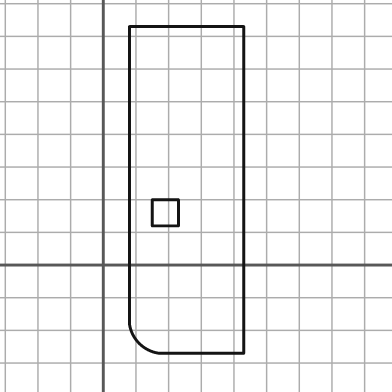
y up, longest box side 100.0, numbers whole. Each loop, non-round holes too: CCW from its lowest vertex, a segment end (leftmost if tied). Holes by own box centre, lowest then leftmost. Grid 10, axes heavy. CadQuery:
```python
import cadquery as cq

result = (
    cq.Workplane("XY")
    .moveTo(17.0, -27.0)
    .lineTo(43.0, -27.0)
    .lineTo(43.0, 73.0)
    .lineTo(8.0, 73.0)
    .lineTo(8.0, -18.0)
    .threePointArc((11.0, -24.0), (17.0, -27.0))
    .close()
    .moveTo(15.0, 12.0)
    .lineTo(23.0, 12.0)
    .lineTo(23.0, 20.0)
    .lineTo(15.0, 20.0)
    .close()
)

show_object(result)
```